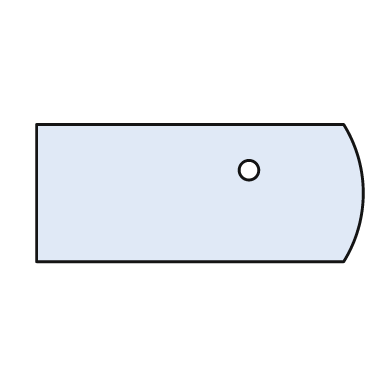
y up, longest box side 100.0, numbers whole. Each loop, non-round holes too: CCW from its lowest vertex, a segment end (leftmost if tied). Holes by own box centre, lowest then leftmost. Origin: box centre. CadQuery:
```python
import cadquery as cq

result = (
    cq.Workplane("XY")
    .moveTo(-50.0, -21.0)
    .lineTo(44.0, -21.0)
    .threePointArc((50.0, 0.0), (44.0, 21.0))
    .lineTo(-50.0, 21.0)
    .close()
    .moveTo(15.0, 7.0)
    .circle(3.0)
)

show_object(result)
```